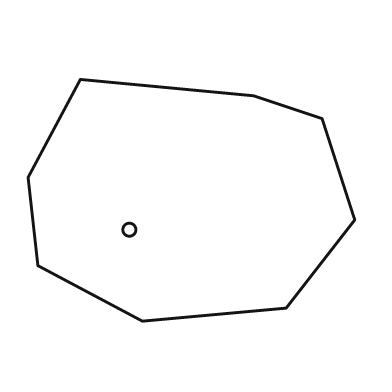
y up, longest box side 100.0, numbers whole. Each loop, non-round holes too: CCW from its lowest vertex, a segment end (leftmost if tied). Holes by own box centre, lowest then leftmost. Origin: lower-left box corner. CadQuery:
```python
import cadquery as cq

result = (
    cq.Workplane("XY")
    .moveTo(35.0, 0.0)
    .lineTo(79.0, 4.0)
    .lineTo(100.0, 31.0)
    .lineTo(90.0, 62.0)
    .lineTo(69.0, 69.0)
    .lineTo(16.0, 74.0)
    .lineTo(0.0, 44.0)
    .lineTo(3.0, 17.0)
    .close()
    .moveTo(31.0, 28.0)
    .circle(2.0)
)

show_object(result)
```